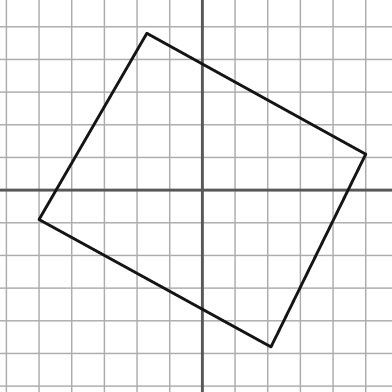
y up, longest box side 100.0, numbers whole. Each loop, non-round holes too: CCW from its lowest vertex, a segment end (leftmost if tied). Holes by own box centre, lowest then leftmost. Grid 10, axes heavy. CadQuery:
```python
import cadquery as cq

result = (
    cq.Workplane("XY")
    .moveTo(21.0, -48.0)
    .lineTo(50.0, 11.0)
    .lineTo(-17.0, 48.0)
    .lineTo(-50.0, -9.0)
    .close()
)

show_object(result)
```